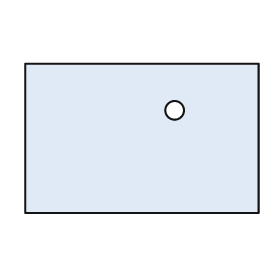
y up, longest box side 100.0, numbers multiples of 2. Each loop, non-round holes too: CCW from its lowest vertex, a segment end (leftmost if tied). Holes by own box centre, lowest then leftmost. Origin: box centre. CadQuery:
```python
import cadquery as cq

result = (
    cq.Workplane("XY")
    .moveTo(-50.0, -32.0)
    .lineTo(50.0, -32.0)
    .lineTo(50.0, 32.0)
    .lineTo(-50.0, 32.0)
    .close()
    .moveTo(14.0, 12.0)
    .circle(4.0)
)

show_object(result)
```